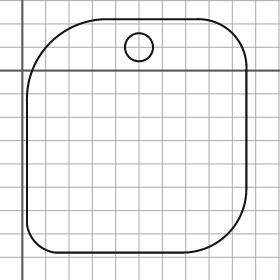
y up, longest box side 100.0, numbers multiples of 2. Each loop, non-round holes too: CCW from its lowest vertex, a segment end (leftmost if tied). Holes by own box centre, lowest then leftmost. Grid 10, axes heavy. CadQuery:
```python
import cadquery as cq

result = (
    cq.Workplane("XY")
    .moveTo(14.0, -78.0)
    .lineTo(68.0, -78.0)
    .threePointArc((88.0, -70.0), (96.0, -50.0))
    .lineTo(96.0, 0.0)
    .threePointArc((90.0, 16.0), (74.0, 22.0))
    .lineTo(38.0, 22.0)
    .threePointArc((12.0, 12.0), (2.0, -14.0))
    .lineTo(2.0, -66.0)
    .threePointArc((6.0, -74.0), (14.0, -78.0))
    .close()
    .moveTo(50.0, 10.0)
    .circle(6.0)
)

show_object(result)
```